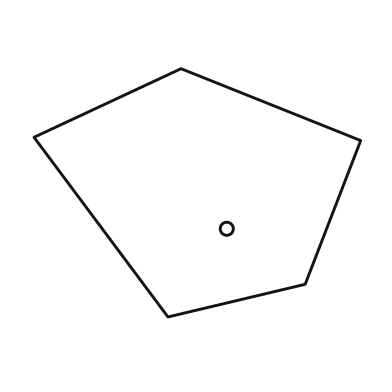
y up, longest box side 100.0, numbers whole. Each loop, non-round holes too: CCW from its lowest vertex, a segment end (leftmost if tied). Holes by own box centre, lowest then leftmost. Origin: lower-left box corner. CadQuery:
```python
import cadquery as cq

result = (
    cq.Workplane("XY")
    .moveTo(41.0, 0.0)
    .lineTo(83.0, 10.0)
    .lineTo(100.0, 54.0)
    .lineTo(45.0, 76.0)
    .lineTo(0.0, 55.0)
    .close()
    .moveTo(59.0, 27.0)
    .circle(2.0)
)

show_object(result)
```